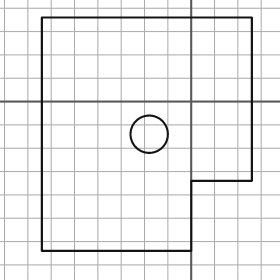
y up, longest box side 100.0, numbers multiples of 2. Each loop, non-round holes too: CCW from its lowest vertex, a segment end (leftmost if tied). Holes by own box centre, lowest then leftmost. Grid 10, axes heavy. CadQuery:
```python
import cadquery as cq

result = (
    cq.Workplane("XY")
    .moveTo(-64.0, -64.0)
    .lineTo(0.0, -64.0)
    .lineTo(0.0, -34.0)
    .lineTo(26.0, -34.0)
    .lineTo(26.0, 36.0)
    .lineTo(-64.0, 36.0)
    .close()
    .moveTo(-18.0, -14.0)
    .circle(8.0)
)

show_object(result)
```